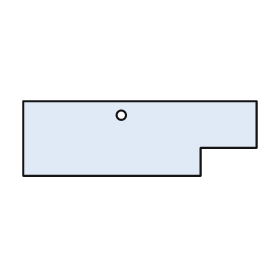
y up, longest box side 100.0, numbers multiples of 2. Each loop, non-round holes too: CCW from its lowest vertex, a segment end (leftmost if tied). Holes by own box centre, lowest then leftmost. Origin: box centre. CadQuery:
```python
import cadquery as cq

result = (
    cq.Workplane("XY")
    .moveTo(-50.0, -16.0)
    .lineTo(26.0, -16.0)
    .lineTo(26.0, -4.0)
    .lineTo(50.0, -4.0)
    .lineTo(50.0, 16.0)
    .lineTo(-50.0, 16.0)
    .close()
    .moveTo(-8.0, 10.0)
    .circle(2.0)
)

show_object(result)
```